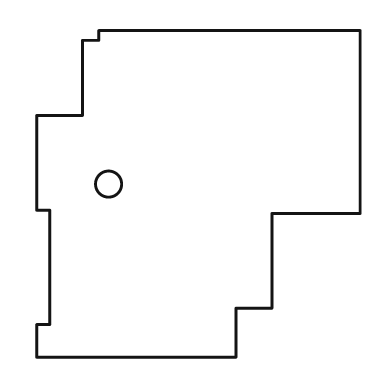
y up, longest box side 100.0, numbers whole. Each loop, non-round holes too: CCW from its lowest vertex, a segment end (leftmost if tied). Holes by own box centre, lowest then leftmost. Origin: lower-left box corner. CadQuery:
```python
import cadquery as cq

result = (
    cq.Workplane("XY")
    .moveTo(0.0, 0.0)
    .lineTo(61.0, 0.0)
    .lineTo(61.0, 15.0)
    .lineTo(72.0, 15.0)
    .lineTo(72.0, 44.0)
    .lineTo(99.0, 44.0)
    .lineTo(99.0, 100.0)
    .lineTo(19.0, 100.0)
    .lineTo(19.0, 97.0)
    .lineTo(14.0, 97.0)
    .lineTo(14.0, 74.0)
    .lineTo(0.0, 74.0)
    .lineTo(0.0, 45.0)
    .lineTo(4.0, 45.0)
    .lineTo(4.0, 10.0)
    .lineTo(0.0, 10.0)
    .close()
    .moveTo(22.0, 53.0)
    .circle(4.0)
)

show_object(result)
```